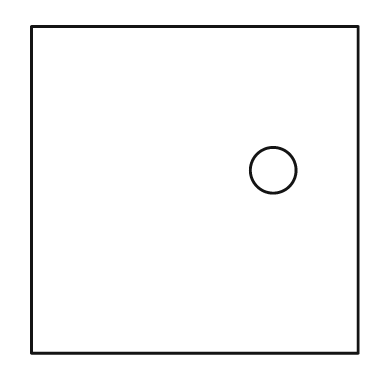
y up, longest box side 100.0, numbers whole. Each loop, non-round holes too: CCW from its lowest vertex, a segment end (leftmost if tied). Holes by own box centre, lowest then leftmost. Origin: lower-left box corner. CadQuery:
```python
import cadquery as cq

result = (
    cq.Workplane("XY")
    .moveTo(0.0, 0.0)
    .lineTo(100.0, 0.0)
    .lineTo(100.0, 100.0)
    .lineTo(0.0, 100.0)
    .close()
    .moveTo(74.0, 56.0)
    .circle(7.0)
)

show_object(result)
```